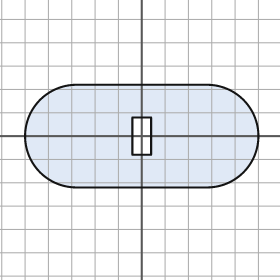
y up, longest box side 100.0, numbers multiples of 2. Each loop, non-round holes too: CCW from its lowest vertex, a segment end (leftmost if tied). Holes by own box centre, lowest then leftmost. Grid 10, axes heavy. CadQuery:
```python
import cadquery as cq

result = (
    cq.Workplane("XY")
    .moveTo(-28.0, -22.0)
    .lineTo(28.0, -22.0)
    .threePointArc((50.0, 0.0), (28.0, 22.0))
    .lineTo(-28.0, 22.0)
    .threePointArc((-50.0, 0.0), (-28.0, -22.0))
    .close()
    .moveTo(-4.0, -8.0)
    .lineTo(4.0, -8.0)
    .lineTo(4.0, 8.0)
    .lineTo(-4.0, 8.0)
    .close()
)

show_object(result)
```